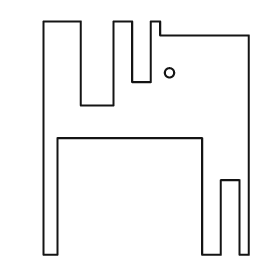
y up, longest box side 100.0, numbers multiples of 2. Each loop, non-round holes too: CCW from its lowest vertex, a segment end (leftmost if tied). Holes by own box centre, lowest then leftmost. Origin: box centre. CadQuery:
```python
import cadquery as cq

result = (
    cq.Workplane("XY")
    .moveTo(-44.0, -50.0)
    .lineTo(-38.0, -50.0)
    .lineTo(-38.0, 0.0)
    .lineTo(24.0, 0.0)
    .lineTo(24.0, -50.0)
    .lineTo(32.0, -50.0)
    .lineTo(32.0, -18.0)
    .lineTo(40.0, -18.0)
    .lineTo(40.0, -50.0)
    .lineTo(44.0, -50.0)
    .lineTo(44.0, 44.0)
    .lineTo(6.0, 44.0)
    .lineTo(6.0, 50.0)
    .lineTo(2.0, 50.0)
    .lineTo(2.0, 24.0)
    .lineTo(-6.0, 24.0)
    .lineTo(-6.0, 50.0)
    .lineTo(-14.0, 50.0)
    .lineTo(-14.0, 14.0)
    .lineTo(-28.0, 14.0)
    .lineTo(-28.0, 50.0)
    .lineTo(-44.0, 50.0)
    .close()
    .moveTo(10.0, 28.0)
    .circle(2.0)
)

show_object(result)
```